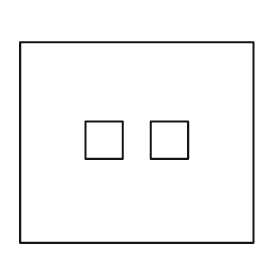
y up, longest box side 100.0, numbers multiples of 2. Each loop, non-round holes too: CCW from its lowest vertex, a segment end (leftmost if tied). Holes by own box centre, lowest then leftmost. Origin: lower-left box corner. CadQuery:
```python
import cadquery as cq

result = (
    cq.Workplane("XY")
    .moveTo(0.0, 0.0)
    .lineTo(100.0, 0.0)
    .lineTo(100.0, 86.0)
    .lineTo(0.0, 86.0)
    .close()
    .moveTo(28.0, 36.0)
    .lineTo(44.0, 36.0)
    .lineTo(44.0, 52.0)
    .lineTo(28.0, 52.0)
    .close()
    .moveTo(56.0, 36.0)
    .lineTo(72.0, 36.0)
    .lineTo(72.0, 52.0)
    .lineTo(56.0, 52.0)
    .close()
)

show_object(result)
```